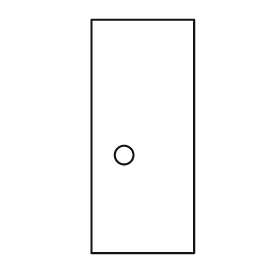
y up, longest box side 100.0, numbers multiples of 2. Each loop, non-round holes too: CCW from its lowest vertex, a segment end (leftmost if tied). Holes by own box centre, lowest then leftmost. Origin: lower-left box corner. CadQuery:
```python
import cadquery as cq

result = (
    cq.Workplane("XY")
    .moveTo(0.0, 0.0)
    .lineTo(44.0, 0.0)
    .lineTo(44.0, 100.0)
    .lineTo(0.0, 100.0)
    .close()
    .moveTo(14.0, 42.0)
    .circle(4.0)
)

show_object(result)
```